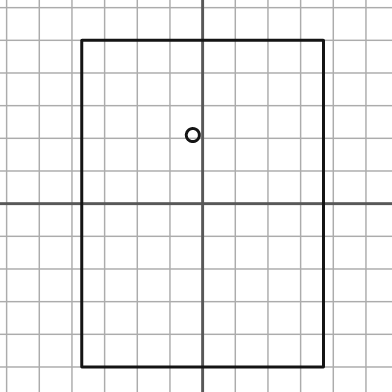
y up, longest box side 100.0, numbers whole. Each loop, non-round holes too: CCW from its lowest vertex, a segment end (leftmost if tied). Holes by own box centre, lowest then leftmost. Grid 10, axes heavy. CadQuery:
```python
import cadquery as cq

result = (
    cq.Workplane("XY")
    .moveTo(-37.0, -50.0)
    .lineTo(37.0, -50.0)
    .lineTo(37.0, 50.0)
    .lineTo(-37.0, 50.0)
    .close()
    .moveTo(-3.0, 21.0)
    .circle(2.0)
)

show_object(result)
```